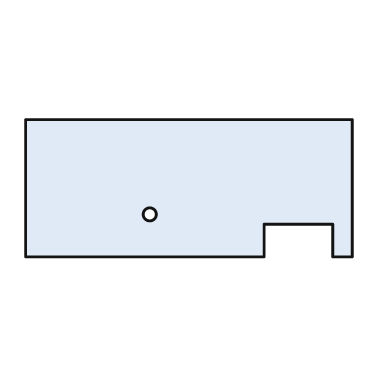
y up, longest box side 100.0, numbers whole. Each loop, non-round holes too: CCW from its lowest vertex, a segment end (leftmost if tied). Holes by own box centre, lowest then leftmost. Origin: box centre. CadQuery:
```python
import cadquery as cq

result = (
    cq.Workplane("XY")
    .moveTo(-50.0, -21.0)
    .lineTo(23.0, -21.0)
    .lineTo(23.0, -11.0)
    .lineTo(44.0, -11.0)
    .lineTo(44.0, -21.0)
    .lineTo(50.0, -21.0)
    .lineTo(50.0, 21.0)
    .lineTo(-50.0, 21.0)
    .close()
    .moveTo(-12.0, -8.0)
    .circle(2.0)
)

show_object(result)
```